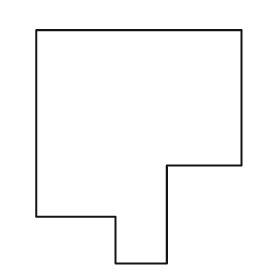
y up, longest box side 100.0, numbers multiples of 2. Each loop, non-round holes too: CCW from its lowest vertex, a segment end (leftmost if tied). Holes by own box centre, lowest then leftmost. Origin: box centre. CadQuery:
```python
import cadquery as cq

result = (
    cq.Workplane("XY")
    .moveTo(-10.0, -50.0)
    .lineTo(12.0, -50.0)
    .lineTo(12.0, -8.0)
    .lineTo(44.0, -8.0)
    .lineTo(44.0, 50.0)
    .lineTo(-44.0, 50.0)
    .lineTo(-44.0, -30.0)
    .lineTo(-10.0, -30.0)
    .close()
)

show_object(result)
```